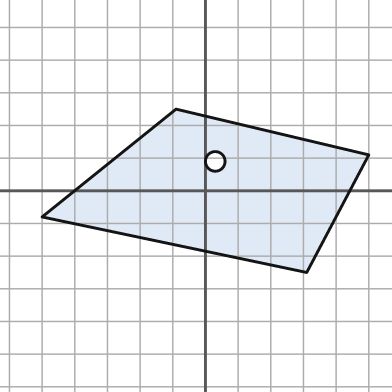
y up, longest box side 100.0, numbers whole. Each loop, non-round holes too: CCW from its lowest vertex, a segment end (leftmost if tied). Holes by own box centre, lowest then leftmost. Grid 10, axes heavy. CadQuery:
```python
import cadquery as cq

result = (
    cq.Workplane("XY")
    .moveTo(31.0, -25.0)
    .lineTo(50.0, 11.0)
    .lineTo(-9.0, 25.0)
    .lineTo(-50.0, -8.0)
    .close()
    .moveTo(3.0, 9.0)
    .circle(3.0)
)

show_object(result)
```